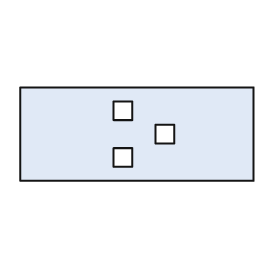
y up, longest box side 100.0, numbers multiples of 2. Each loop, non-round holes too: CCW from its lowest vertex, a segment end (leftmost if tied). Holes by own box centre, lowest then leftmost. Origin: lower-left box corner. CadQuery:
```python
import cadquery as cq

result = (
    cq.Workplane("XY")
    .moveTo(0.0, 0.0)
    .lineTo(100.0, 0.0)
    .lineTo(100.0, 40.0)
    .lineTo(0.0, 40.0)
    .close()
    .moveTo(40.0, 6.0)
    .lineTo(48.0, 6.0)
    .lineTo(48.0, 14.0)
    .lineTo(40.0, 14.0)
    .close()
    .moveTo(58.0, 16.0)
    .lineTo(66.0, 16.0)
    .lineTo(66.0, 24.0)
    .lineTo(58.0, 24.0)
    .close()
    .moveTo(40.0, 26.0)
    .lineTo(48.0, 26.0)
    .lineTo(48.0, 34.0)
    .lineTo(40.0, 34.0)
    .close()
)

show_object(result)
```